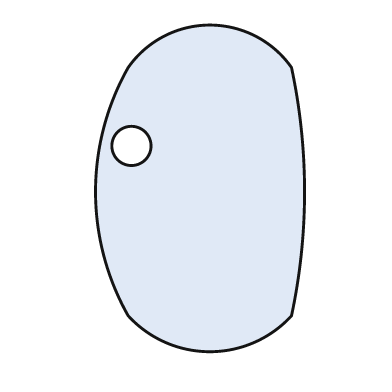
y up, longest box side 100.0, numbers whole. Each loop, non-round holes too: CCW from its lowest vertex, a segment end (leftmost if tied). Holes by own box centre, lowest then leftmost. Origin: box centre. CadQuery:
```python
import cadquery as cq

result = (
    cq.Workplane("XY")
    .moveTo(-22.0, -39.0)
    .threePointArc((3.0, -50.0), (28.0, -39.0))
    .threePointArc((32.0, -1.0), (28.0, 37.0))
    .threePointArc((3.0, 50.0), (-22.0, 37.0))
    .threePointArc((-32.0, -1.0), (-22.0, -39.0))
    .close()
    .moveTo(-21.0, 13.0)
    .circle(6.0)
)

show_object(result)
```